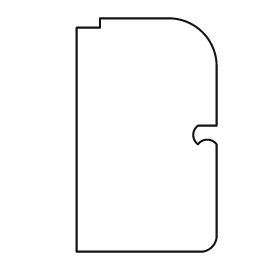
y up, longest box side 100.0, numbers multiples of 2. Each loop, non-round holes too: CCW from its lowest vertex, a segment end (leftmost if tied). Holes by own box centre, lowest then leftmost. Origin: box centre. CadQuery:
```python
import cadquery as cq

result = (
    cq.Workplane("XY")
    .moveTo(-30.0, -50.0)
    .lineTo(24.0, -50.0)
    .threePointArc((28.0, -48.0), (30.0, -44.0))
    .lineTo(30.0, -4.0)
    .threePointArc((26.0, -2.0), (22.0, -4.0))
    .threePointArc((20.0, 0.0), (22.0, 4.0))
    .lineTo(30.0, 4.0)
    .lineTo(30.0, 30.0)
    .threePointArc((24.0, 44.0), (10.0, 50.0))
    .lineTo(-20.0, 50.0)
    .lineTo(-20.0, 46.0)
    .lineTo(-30.0, 46.0)
    .close()
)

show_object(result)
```